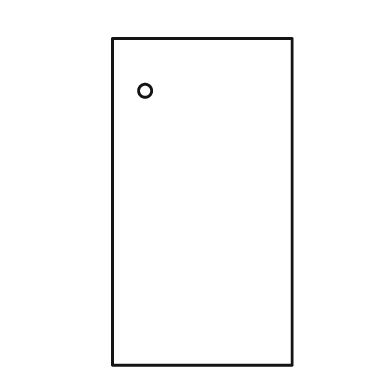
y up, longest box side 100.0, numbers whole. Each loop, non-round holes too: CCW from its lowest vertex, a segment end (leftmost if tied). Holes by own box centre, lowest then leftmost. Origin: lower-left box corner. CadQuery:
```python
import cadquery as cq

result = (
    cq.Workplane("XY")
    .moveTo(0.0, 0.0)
    .lineTo(55.0, 0.0)
    .lineTo(55.0, 100.0)
    .lineTo(0.0, 100.0)
    .close()
    .moveTo(10.0, 84.0)
    .circle(2.0)
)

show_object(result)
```